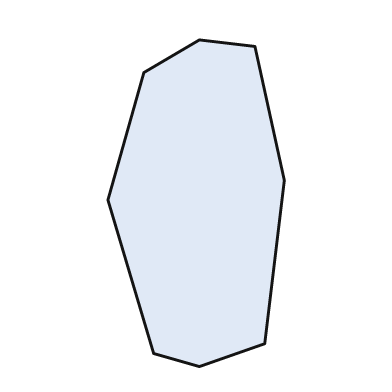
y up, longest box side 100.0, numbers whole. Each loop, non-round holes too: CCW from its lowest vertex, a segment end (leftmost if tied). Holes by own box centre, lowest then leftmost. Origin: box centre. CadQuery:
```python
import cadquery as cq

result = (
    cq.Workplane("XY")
    .moveTo(1.0, -50.0)
    .lineTo(21.0, -43.0)
    .lineTo(27.0, 7.0)
    .lineTo(18.0, 48.0)
    .lineTo(1.0, 50.0)
    .lineTo(-16.0, 40.0)
    .lineTo(-27.0, 1.0)
    .lineTo(-13.0, -46.0)
    .close()
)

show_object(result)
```